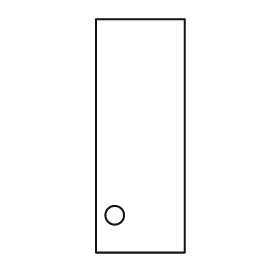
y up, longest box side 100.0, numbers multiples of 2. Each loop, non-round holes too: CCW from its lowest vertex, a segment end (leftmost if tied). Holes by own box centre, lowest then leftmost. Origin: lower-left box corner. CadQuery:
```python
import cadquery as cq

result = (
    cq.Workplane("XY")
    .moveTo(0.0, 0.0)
    .lineTo(38.0, 0.0)
    .lineTo(38.0, 100.0)
    .lineTo(0.0, 100.0)
    .close()
    .moveTo(8.0, 16.0)
    .circle(4.0)
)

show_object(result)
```